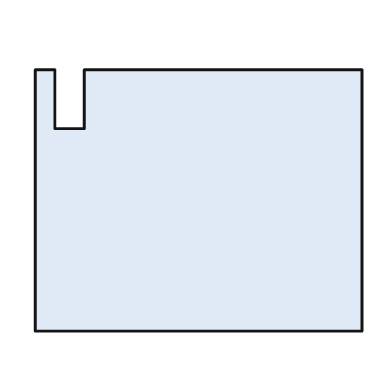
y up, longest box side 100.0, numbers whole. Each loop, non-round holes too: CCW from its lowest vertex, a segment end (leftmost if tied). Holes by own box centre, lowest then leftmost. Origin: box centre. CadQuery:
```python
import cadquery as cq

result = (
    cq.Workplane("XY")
    .moveTo(-50.0, -40.0)
    .lineTo(50.0, -40.0)
    .lineTo(50.0, 40.0)
    .lineTo(-35.0, 40.0)
    .lineTo(-35.0, 22.0)
    .lineTo(-44.0, 22.0)
    .lineTo(-44.0, 40.0)
    .lineTo(-50.0, 40.0)
    .close()
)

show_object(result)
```